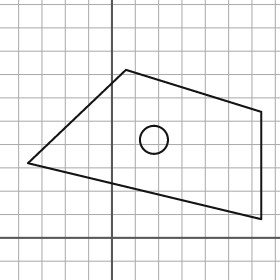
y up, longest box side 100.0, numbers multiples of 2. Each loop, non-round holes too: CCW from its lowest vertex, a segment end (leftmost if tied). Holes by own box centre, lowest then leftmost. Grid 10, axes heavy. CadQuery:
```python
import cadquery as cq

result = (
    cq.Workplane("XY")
    .moveTo(64.0, 8.0)
    .lineTo(64.0, 54.0)
    .lineTo(6.0, 72.0)
    .lineTo(-36.0, 32.0)
    .close()
    .moveTo(18.0, 42.0)
    .circle(6.0)
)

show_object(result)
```